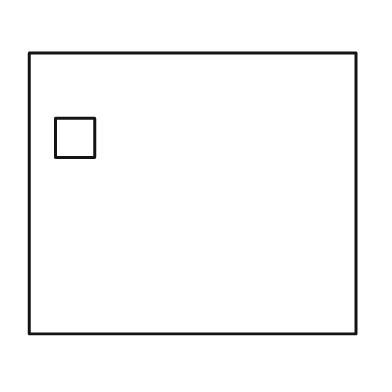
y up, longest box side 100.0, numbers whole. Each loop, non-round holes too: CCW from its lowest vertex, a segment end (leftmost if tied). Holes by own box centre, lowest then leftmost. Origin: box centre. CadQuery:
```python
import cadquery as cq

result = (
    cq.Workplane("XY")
    .moveTo(-50.0, -43.0)
    .lineTo(50.0, -43.0)
    .lineTo(50.0, 43.0)
    .lineTo(-50.0, 43.0)
    .close()
    .moveTo(-42.0, 11.0)
    .lineTo(-30.0, 11.0)
    .lineTo(-30.0, 23.0)
    .lineTo(-42.0, 23.0)
    .close()
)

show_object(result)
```